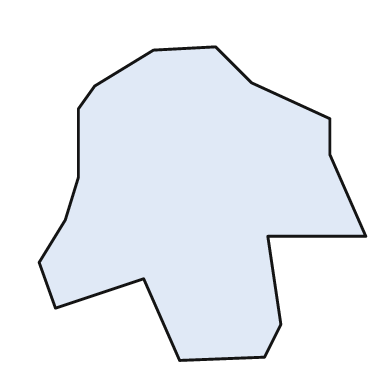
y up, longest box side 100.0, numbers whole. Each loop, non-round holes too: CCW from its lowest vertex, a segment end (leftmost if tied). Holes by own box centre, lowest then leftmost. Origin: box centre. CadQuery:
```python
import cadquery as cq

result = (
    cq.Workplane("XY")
    .moveTo(-7.0, -48.0)
    .lineTo(19.0, -47.0)
    .lineTo(24.0, -37.0)
    .lineTo(20.0, -10.0)
    .lineTo(50.0, -10.0)
    .lineTo(39.0, 15.0)
    .lineTo(39.0, 26.0)
    .lineTo(15.0, 37.0)
    .lineTo(4.0, 48.0)
    .lineTo(-15.0, 47.0)
    .lineTo(-33.0, 36.0)
    .lineTo(-38.0, 29.0)
    .lineTo(-38.0, 8.0)
    .lineTo(-42.0, -5.0)
    .lineTo(-50.0, -18.0)
    .lineTo(-45.0, -32.0)
    .lineTo(-18.0, -23.0)
    .close()
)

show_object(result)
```